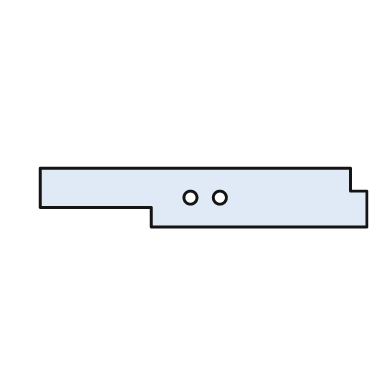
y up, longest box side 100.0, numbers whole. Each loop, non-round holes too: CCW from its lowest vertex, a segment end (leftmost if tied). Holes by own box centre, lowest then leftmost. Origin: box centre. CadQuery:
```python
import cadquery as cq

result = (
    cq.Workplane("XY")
    .moveTo(-16.0, -9.0)
    .lineTo(50.0, -9.0)
    .lineTo(50.0, 2.0)
    .lineTo(45.0, 2.0)
    .lineTo(45.0, 9.0)
    .lineTo(-50.0, 9.0)
    .lineTo(-50.0, -3.0)
    .lineTo(-16.0, -3.0)
    .close()
    .moveTo(-4.0, 0.0)
    .circle(2.0)
    .moveTo(5.0, 0.0)
    .circle(2.0)
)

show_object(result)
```